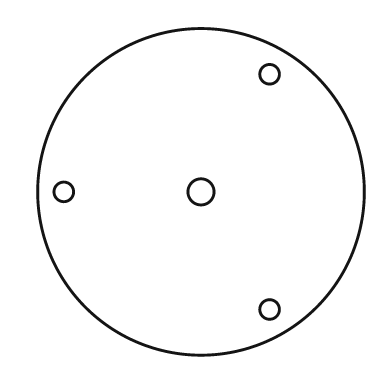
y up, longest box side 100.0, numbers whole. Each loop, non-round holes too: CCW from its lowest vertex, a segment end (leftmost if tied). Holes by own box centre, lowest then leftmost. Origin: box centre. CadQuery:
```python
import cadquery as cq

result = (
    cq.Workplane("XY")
    .moveTo(0.0, 0.0)
    .circle(50.0)
    .moveTo(21.0, -36.0)
    .circle(3.0)
    .moveTo(-42.0, 0.0)
    .circle(3.0)
    .moveTo(0.0, 0.0)
    .circle(4.0)
    .moveTo(21.0, 36.0)
    .circle(3.0)
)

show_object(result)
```